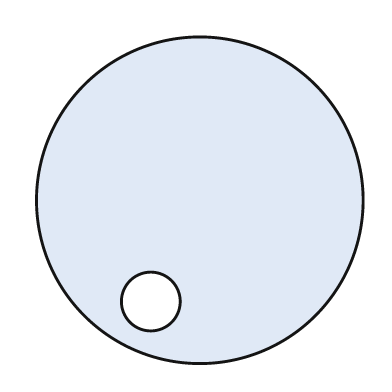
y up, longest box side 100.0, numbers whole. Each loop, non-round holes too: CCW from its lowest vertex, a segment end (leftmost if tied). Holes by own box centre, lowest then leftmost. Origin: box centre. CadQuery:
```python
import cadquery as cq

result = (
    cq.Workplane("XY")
    .moveTo(0.0, 0.0)
    .circle(50.0)
    .moveTo(-15.0, -31.0)
    .circle(9.0)
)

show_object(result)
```